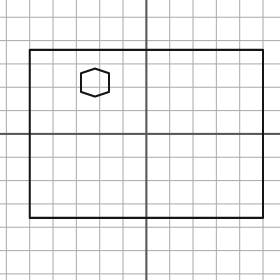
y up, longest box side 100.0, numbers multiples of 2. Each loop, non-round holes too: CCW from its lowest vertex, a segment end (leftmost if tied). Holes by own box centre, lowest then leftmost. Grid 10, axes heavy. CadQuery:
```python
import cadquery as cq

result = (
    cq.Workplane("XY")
    .moveTo(-50.0, -36.0)
    .lineTo(50.0, -36.0)
    .lineTo(50.0, 36.0)
    .lineTo(-50.0, 36.0)
    .close()
    .moveTo(-22.0, 16.0)
    .lineTo(-16.0, 18.0)
    .lineTo(-16.0, 26.0)
    .lineTo(-22.0, 28.0)
    .lineTo(-28.0, 26.0)
    .lineTo(-28.0, 18.0)
    .close()
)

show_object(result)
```